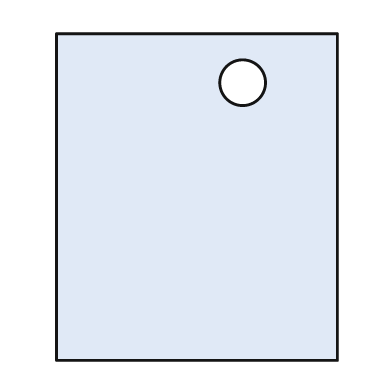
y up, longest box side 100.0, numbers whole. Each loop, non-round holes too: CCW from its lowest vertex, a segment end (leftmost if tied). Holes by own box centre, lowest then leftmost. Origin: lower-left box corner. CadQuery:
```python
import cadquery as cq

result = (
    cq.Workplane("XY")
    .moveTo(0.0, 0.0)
    .lineTo(86.0, 0.0)
    .lineTo(86.0, 100.0)
    .lineTo(0.0, 100.0)
    .close()
    .moveTo(57.0, 85.0)
    .circle(7.0)
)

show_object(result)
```